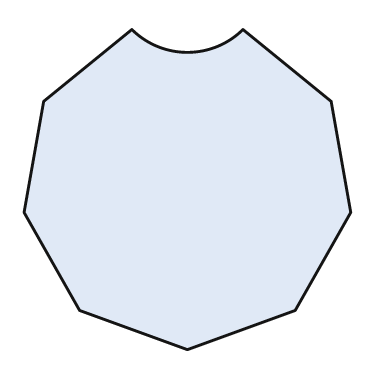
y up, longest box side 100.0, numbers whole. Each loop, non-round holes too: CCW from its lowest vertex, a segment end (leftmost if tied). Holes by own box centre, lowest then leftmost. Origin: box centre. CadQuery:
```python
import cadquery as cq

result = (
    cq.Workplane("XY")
    .moveTo(0.0, -49.0)
    .lineTo(33.0, -37.0)
    .lineTo(50.0, -7.0)
    .lineTo(44.0, 27.0)
    .lineTo(17.0, 49.0)
    .threePointArc((0.0, 42.0), (-17.0, 49.0))
    .lineTo(-44.0, 27.0)
    .lineTo(-50.0, -7.0)
    .lineTo(-33.0, -37.0)
    .close()
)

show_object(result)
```